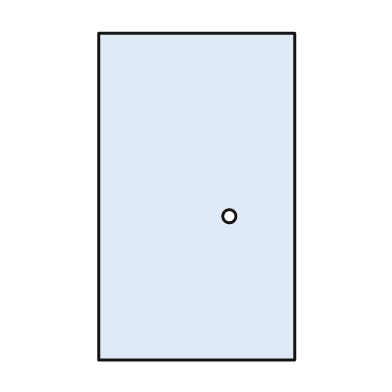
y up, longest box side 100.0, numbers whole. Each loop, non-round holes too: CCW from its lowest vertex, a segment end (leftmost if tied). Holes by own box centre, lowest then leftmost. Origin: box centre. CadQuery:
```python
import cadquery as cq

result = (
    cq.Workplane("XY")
    .moveTo(-30.0, -50.0)
    .lineTo(30.0, -50.0)
    .lineTo(30.0, 50.0)
    .lineTo(-30.0, 50.0)
    .close()
    .moveTo(10.0, -6.0)
    .circle(2.0)
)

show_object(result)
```